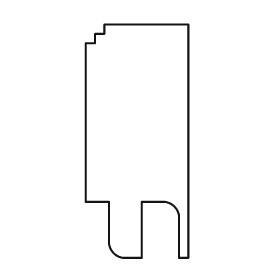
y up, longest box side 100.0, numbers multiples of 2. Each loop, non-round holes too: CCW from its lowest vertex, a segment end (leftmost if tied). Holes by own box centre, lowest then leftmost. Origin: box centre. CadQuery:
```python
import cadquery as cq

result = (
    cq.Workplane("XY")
    .moveTo(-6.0, -50.0)
    .lineTo(2.0, -50.0)
    .lineTo(2.0, -26.0)
    .lineTo(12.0, -26.0)
    .threePointArc((16.0, -28.0), (18.0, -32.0))
    .lineTo(18.0, -50.0)
    .lineTo(22.0, -50.0)
    .lineTo(22.0, 50.0)
    .lineTo(-14.0, 50.0)
    .lineTo(-14.0, 46.0)
    .lineTo(-18.0, 46.0)
    .lineTo(-18.0, 42.0)
    .lineTo(-22.0, 42.0)
    .lineTo(-22.0, -26.0)
    .lineTo(-12.0, -26.0)
    .lineTo(-12.0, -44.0)
    .threePointArc((-10.0, -48.0), (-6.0, -50.0))
    .close()
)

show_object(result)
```